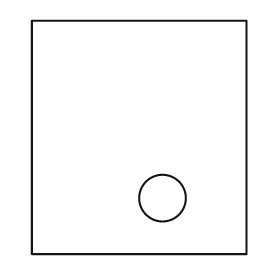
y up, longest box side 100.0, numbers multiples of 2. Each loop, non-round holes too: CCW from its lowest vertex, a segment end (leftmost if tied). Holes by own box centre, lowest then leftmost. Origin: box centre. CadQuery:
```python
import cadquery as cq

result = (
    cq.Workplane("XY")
    .moveTo(-46.0, -50.0)
    .lineTo(46.0, -50.0)
    .lineTo(46.0, 50.0)
    .lineTo(-46.0, 50.0)
    .close()
    .moveTo(10.0, -26.0)
    .circle(10.0)
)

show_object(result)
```